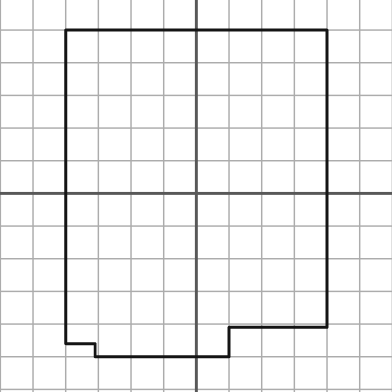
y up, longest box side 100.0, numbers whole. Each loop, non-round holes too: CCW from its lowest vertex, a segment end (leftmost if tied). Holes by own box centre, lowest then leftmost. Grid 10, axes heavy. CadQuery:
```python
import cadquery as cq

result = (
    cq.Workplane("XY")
    .moveTo(-31.0, -50.0)
    .lineTo(10.0, -50.0)
    .lineTo(10.0, -41.0)
    .lineTo(40.0, -41.0)
    .lineTo(40.0, 50.0)
    .lineTo(-40.0, 50.0)
    .lineTo(-40.0, -46.0)
    .lineTo(-31.0, -46.0)
    .close()
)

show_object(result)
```